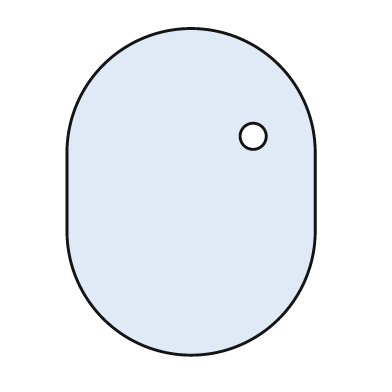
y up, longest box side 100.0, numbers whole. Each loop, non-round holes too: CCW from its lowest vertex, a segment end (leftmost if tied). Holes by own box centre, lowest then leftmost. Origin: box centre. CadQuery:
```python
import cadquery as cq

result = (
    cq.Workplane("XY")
    .moveTo(-38.0, -12.0)
    .threePointArc((0.0, -50.0), (38.0, -12.0))
    .lineTo(38.0, 12.0)
    .threePointArc((0.0, 50.0), (-38.0, 12.0))
    .close()
    .moveTo(19.0, 17.0)
    .circle(4.0)
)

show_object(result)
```